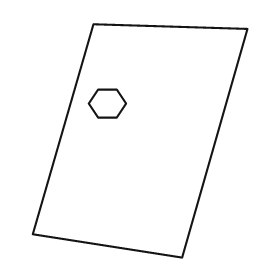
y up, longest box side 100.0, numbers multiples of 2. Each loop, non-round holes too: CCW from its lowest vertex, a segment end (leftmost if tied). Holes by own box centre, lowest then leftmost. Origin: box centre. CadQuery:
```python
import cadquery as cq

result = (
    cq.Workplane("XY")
    .moveTo(18.0, -50.0)
    .lineTo(46.0, 48.0)
    .lineTo(-20.0, 50.0)
    .lineTo(-46.0, -40.0)
    .close()
    .moveTo(-18.0, 10.0)
    .lineTo(-10.0, 10.0)
    .lineTo(-6.0, 16.0)
    .lineTo(-10.0, 22.0)
    .lineTo(-18.0, 22.0)
    .lineTo(-22.0, 16.0)
    .close()
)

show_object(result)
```